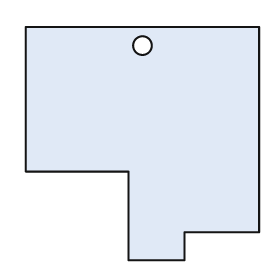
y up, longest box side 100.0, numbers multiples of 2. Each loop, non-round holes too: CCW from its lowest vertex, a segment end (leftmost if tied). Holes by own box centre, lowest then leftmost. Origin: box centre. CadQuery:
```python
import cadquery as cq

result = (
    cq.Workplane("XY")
    .moveTo(-6.0, -50.0)
    .lineTo(18.0, -50.0)
    .lineTo(18.0, -38.0)
    .lineTo(50.0, -38.0)
    .lineTo(50.0, 50.0)
    .lineTo(-50.0, 50.0)
    .lineTo(-50.0, -12.0)
    .lineTo(-6.0, -12.0)
    .close()
    .moveTo(0.0, 42.0)
    .circle(4.0)
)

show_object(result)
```